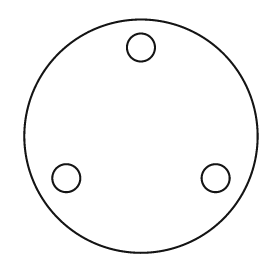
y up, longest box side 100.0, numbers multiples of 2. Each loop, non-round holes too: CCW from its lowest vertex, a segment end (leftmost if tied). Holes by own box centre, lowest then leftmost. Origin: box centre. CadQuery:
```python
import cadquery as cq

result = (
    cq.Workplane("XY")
    .moveTo(0.0, 0.0)
    .circle(50.0)
    .moveTo(-32.0, -18.0)
    .circle(6.0)
    .moveTo(32.0, -18.0)
    .circle(6.0)
    .moveTo(0.0, 38.0)
    .circle(6.0)
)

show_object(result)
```